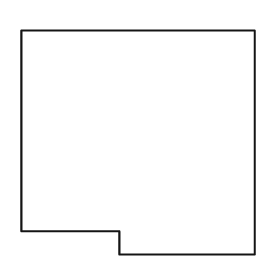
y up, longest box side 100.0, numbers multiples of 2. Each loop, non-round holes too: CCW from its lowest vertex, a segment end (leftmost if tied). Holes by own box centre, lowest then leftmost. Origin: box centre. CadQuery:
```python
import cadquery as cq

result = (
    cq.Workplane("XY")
    .moveTo(-8.0, -48.0)
    .lineTo(50.0, -48.0)
    .lineTo(50.0, 48.0)
    .lineTo(-50.0, 48.0)
    .lineTo(-50.0, -38.0)
    .lineTo(-8.0, -38.0)
    .close()
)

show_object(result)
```